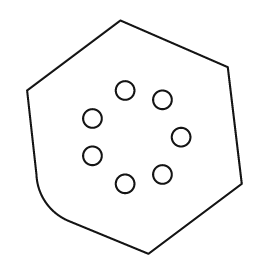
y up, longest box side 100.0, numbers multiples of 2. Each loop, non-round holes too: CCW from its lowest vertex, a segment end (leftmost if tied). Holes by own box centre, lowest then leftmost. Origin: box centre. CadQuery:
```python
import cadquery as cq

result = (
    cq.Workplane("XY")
    .moveTo(6.0, -50.0)
    .lineTo(46.0, -20.0)
    .lineTo(40.0, 30.0)
    .lineTo(-6.0, 50.0)
    .lineTo(-46.0, 20.0)
    .lineTo(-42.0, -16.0)
    .threePointArc((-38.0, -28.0), (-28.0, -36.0))
    .close()
    .moveTo(-4.0, -20.0)
    .circle(4.0)
    .moveTo(12.0, -16.0)
    .circle(4.0)
    .moveTo(-18.0, -8.0)
    .circle(4.0)
    .moveTo(20.0, 0.0)
    .circle(4.0)
    .moveTo(-18.0, 8.0)
    .circle(4.0)
    .moveTo(12.0, 16.0)
    .circle(4.0)
    .moveTo(-4.0, 20.0)
    .circle(4.0)
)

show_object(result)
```